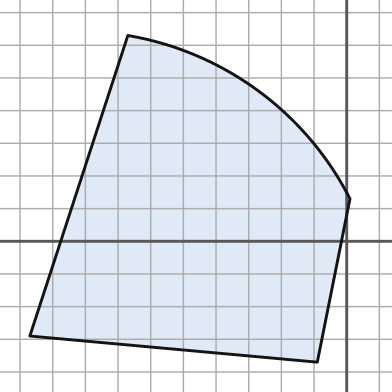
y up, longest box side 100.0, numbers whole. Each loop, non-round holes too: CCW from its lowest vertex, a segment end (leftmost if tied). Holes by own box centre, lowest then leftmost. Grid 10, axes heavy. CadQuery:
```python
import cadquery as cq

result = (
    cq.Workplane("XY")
    .moveTo(-9.0, -37.0)
    .lineTo(1.0, 13.0)
    .threePointArc((-27.0, 46.0), (-67.0, 63.0))
    .lineTo(-97.0, -29.0)
    .close()
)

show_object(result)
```